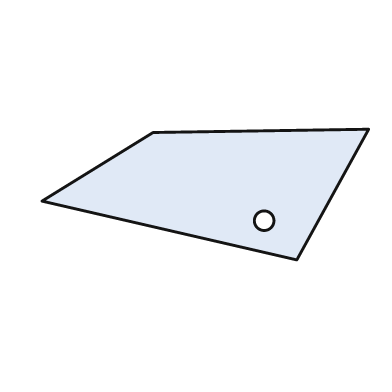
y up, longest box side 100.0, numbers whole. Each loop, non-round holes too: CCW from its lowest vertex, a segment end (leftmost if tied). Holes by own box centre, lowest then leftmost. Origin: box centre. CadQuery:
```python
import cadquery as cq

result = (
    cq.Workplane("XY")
    .moveTo(28.0, -20.0)
    .lineTo(50.0, 20.0)
    .lineTo(-16.0, 19.0)
    .lineTo(-50.0, -2.0)
    .close()
    .moveTo(18.0, -8.0)
    .circle(3.0)
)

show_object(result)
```